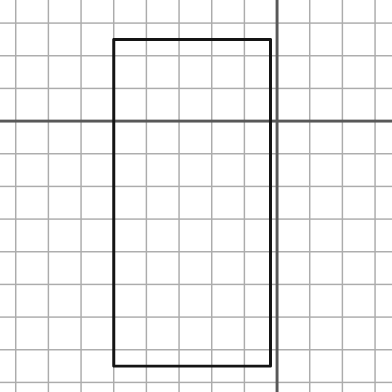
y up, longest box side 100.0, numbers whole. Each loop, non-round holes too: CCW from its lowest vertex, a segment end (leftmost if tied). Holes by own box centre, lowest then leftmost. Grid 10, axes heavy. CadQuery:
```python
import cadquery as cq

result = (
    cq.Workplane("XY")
    .moveTo(-50.0, -75.0)
    .lineTo(-2.0, -75.0)
    .lineTo(-2.0, 25.0)
    .lineTo(-50.0, 25.0)
    .close()
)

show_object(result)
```